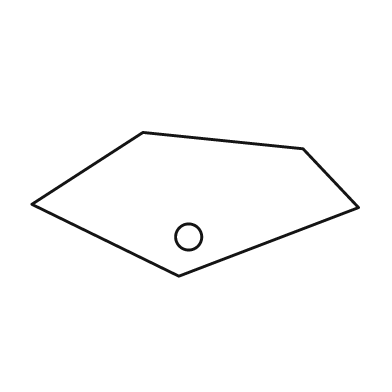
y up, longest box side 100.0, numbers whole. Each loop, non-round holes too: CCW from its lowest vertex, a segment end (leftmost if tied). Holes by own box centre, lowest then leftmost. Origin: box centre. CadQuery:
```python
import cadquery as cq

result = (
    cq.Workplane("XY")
    .moveTo(-5.0, -22.0)
    .lineTo(50.0, -1.0)
    .lineTo(33.0, 17.0)
    .lineTo(-16.0, 22.0)
    .lineTo(-50.0, 0.0)
    .close()
    .moveTo(-2.0, -10.0)
    .circle(4.0)
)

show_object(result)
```